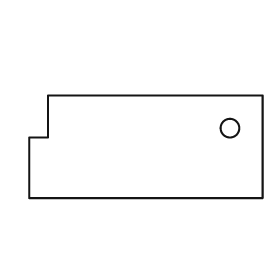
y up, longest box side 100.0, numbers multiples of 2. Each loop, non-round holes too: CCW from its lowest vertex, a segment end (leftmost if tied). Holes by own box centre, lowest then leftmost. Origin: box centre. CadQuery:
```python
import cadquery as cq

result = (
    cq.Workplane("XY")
    .moveTo(-50.0, -22.0)
    .lineTo(50.0, -22.0)
    .lineTo(50.0, 22.0)
    .lineTo(-42.0, 22.0)
    .lineTo(-42.0, 4.0)
    .lineTo(-50.0, 4.0)
    .close()
    .moveTo(36.0, 8.0)
    .circle(4.0)
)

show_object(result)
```